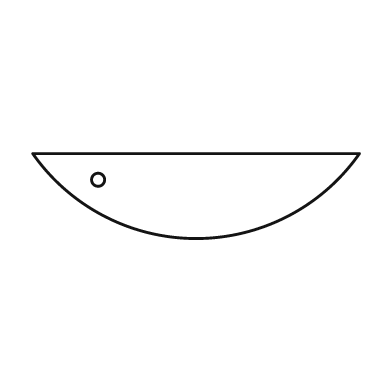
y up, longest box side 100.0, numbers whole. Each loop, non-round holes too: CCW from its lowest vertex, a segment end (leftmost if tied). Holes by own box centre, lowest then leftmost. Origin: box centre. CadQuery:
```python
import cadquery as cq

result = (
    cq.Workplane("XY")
    .moveTo(-50.0, 13.0)
    .threePointArc((0.0, -13.0), (50.0, 13.0))
    .close()
    .moveTo(-30.0, 5.0)
    .circle(2.0)
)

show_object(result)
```